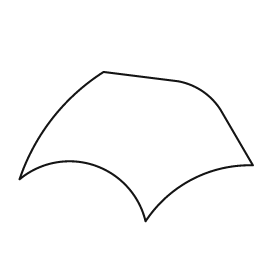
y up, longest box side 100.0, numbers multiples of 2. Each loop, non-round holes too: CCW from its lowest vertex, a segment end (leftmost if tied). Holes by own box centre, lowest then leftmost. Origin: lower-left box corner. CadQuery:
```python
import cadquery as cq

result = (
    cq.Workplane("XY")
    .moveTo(54.0, 0.0)
    .threePointArc((74.0, 18.0), (100.0, 24.0))
    .lineTo(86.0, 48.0)
    .threePointArc((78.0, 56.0), (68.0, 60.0))
    .lineTo(36.0, 64.0)
    .threePointArc((14.0, 44.0), (0.0, 18.0))
    .threePointArc((32.0, 24.0), (54.0, 0.0))
    .close()
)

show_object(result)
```